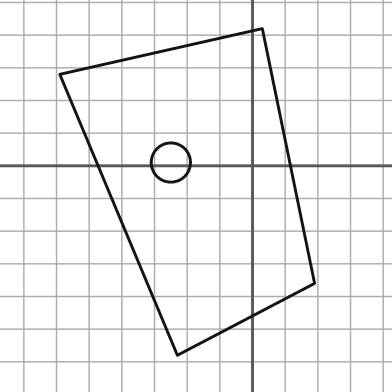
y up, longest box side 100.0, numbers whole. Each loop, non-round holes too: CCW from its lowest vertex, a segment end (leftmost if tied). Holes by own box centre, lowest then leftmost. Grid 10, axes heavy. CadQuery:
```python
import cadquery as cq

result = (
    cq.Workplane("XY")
    .moveTo(-23.0, -58.0)
    .lineTo(19.0, -36.0)
    .lineTo(3.0, 42.0)
    .lineTo(-59.0, 28.0)
    .close()
    .moveTo(-25.0, 1.0)
    .circle(6.0)
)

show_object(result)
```